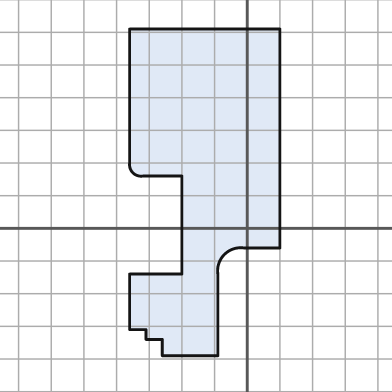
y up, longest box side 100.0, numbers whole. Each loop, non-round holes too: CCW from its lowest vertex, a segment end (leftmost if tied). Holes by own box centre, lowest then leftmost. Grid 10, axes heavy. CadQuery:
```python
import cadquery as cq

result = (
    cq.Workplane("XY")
    .moveTo(-26.0, -39.0)
    .lineTo(-9.0, -39.0)
    .lineTo(-9.0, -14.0)
    .threePointArc((-7.0, -8.0), (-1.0, -6.0))
    .lineTo(10.0, -6.0)
    .lineTo(10.0, 61.0)
    .lineTo(-36.0, 61.0)
    .lineTo(-36.0, 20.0)
    .threePointArc((-35.0, 17.0), (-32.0, 16.0))
    .lineTo(-20.0, 16.0)
    .lineTo(-20.0, -14.0)
    .lineTo(-36.0, -14.0)
    .lineTo(-36.0, -31.0)
    .lineTo(-31.0, -31.0)
    .lineTo(-31.0, -34.0)
    .lineTo(-26.0, -34.0)
    .close()
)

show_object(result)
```